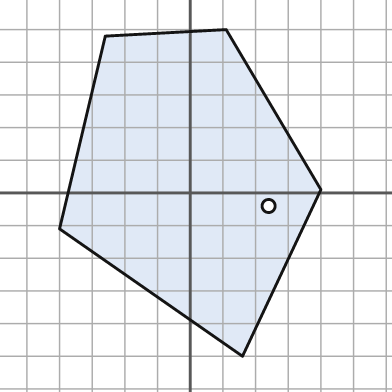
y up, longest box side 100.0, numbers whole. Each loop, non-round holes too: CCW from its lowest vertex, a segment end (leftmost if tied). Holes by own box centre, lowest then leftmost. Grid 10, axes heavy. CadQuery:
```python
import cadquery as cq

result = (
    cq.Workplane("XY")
    .moveTo(16.0, -50.0)
    .lineTo(40.0, 1.0)
    .lineTo(11.0, 50.0)
    .lineTo(-26.0, 48.0)
    .lineTo(-40.0, -11.0)
    .close()
    .moveTo(24.0, -4.0)
    .circle(2.0)
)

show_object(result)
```